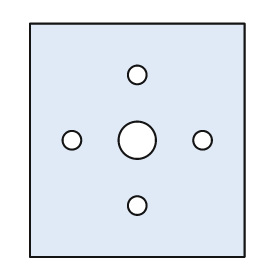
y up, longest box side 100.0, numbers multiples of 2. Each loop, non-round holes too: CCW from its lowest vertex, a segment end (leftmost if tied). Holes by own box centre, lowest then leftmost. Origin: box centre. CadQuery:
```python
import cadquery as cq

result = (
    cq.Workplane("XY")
    .moveTo(-46.0, -50.0)
    .lineTo(46.0, -50.0)
    .lineTo(46.0, 50.0)
    .lineTo(-46.0, 50.0)
    .close()
    .moveTo(0.0, -28.0)
    .circle(4.0)
    .moveTo(-28.0, 0.0)
    .circle(4.0)
    .moveTo(0.0, 0.0)
    .circle(8.0)
    .moveTo(28.0, 0.0)
    .circle(4.0)
    .moveTo(0.0, 28.0)
    .circle(4.0)
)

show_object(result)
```